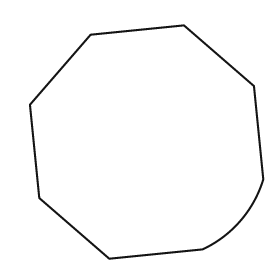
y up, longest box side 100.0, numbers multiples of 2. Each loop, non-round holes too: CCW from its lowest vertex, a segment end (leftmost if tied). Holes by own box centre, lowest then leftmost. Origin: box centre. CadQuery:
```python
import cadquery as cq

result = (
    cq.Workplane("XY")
    .moveTo(-16.0, -50.0)
    .lineTo(24.0, -46.0)
    .threePointArc((40.0, -34.0), (50.0, -16.0))
    .lineTo(46.0, 24.0)
    .lineTo(16.0, 50.0)
    .lineTo(-24.0, 46.0)
    .lineTo(-50.0, 16.0)
    .lineTo(-46.0, -24.0)
    .close()
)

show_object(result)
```